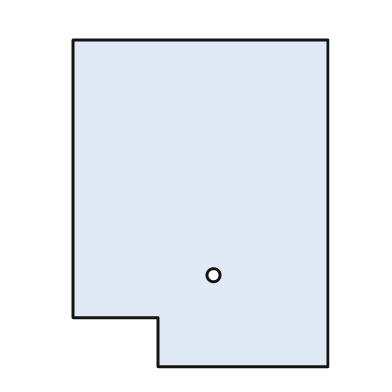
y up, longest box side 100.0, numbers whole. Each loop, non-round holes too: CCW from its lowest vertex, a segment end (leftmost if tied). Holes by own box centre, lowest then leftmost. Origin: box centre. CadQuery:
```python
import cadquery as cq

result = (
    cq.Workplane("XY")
    .moveTo(-13.0, -50.0)
    .lineTo(39.0, -50.0)
    .lineTo(39.0, 50.0)
    .lineTo(-39.0, 50.0)
    .lineTo(-39.0, -35.0)
    .lineTo(-13.0, -35.0)
    .close()
    .moveTo(4.0, -22.0)
    .circle(2.0)
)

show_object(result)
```